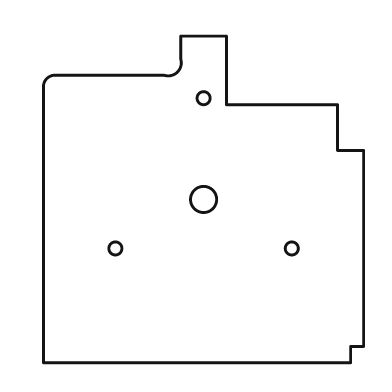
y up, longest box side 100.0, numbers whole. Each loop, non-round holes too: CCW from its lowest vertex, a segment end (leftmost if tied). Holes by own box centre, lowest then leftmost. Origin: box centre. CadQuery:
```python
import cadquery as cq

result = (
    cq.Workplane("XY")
    .moveTo(-49.0, -50.0)
    .lineTo(45.0, -50.0)
    .lineTo(45.0, -45.0)
    .lineTo(49.0, -45.0)
    .lineTo(49.0, 15.0)
    .lineTo(41.0, 15.0)
    .lineTo(41.0, 29.0)
    .lineTo(7.0, 29.0)
    .lineTo(7.0, 50.0)
    .lineTo(-7.0, 50.0)
    .lineTo(-7.0, 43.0)
    .threePointArc((-8.0, 39.0), (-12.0, 38.0))
    .lineTo(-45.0, 38.0)
    .threePointArc((-48.0, 37.0), (-49.0, 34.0))
    .close()
    .moveTo(-27.0, -15.0)
    .circle(2.0)
    .moveTo(27.0, -15.0)
    .circle(2.0)
    .moveTo(0.0, 0.0)
    .circle(4.0)
    .moveTo(0.0, 31.0)
    .circle(2.0)
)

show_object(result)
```